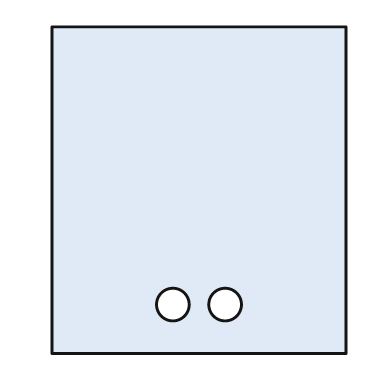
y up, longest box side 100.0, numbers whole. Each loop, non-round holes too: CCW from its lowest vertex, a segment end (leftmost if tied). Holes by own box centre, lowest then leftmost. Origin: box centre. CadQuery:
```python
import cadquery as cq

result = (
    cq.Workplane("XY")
    .moveTo(-45.0, -50.0)
    .lineTo(45.0, -50.0)
    .lineTo(45.0, 50.0)
    .lineTo(-45.0, 50.0)
    .close()
    .moveTo(-8.0, -35.0)
    .circle(5.0)
    .moveTo(8.0, -35.0)
    .circle(5.0)
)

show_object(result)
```